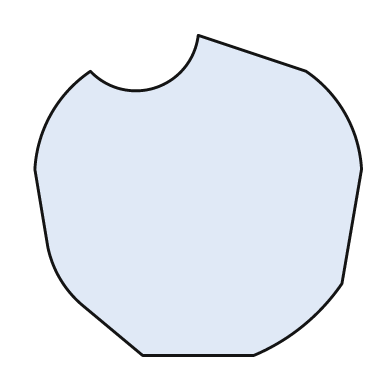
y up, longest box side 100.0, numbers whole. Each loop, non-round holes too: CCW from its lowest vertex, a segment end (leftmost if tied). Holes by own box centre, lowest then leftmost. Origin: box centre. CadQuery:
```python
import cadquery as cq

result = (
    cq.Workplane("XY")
    .moveTo(-17.0, -49.0)
    .lineTo(17.0, -49.0)
    .threePointArc((32.0, -40.0), (44.0, -27.0))
    .lineTo(50.0, 8.0)
    .threePointArc((45.0, 25.0), (33.0, 38.0))
    .lineTo(0.0, 49.0)
    .threePointArc((-13.0, 33.0), (-33.0, 38.0))
    .threePointArc((-45.0, 25.0), (-50.0, 8.0))
    .lineTo(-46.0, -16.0)
    .threePointArc((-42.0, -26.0), (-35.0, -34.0))
    .close()
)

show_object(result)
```